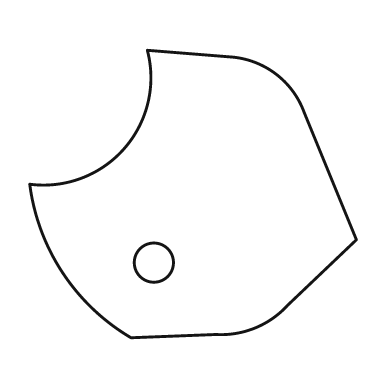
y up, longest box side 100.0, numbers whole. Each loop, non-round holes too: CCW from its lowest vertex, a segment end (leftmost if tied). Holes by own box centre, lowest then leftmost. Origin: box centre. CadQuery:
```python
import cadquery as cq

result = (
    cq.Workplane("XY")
    .moveTo(-19.0, -44.0)
    .lineTo(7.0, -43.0)
    .threePointArc((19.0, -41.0), (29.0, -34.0))
    .lineTo(50.0, -14.0)
    .lineTo(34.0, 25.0)
    .threePointArc((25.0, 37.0), (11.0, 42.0))
    .lineTo(-14.0, 44.0)
    .threePointArc((-21.0, 14.0), (-50.0, 3.0))
    .threePointArc((-40.0, -24.0), (-19.0, -44.0))
    .close()
    .moveTo(-12.0, -21.0)
    .circle(6.0)
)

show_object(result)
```